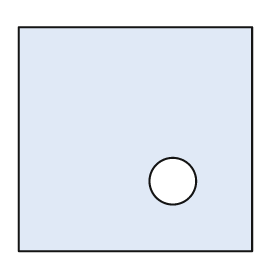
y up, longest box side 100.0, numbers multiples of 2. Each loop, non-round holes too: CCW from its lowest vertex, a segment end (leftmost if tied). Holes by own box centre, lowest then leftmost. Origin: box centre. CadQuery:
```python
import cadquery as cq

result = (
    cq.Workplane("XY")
    .moveTo(-50.0, -48.0)
    .lineTo(50.0, -48.0)
    .lineTo(50.0, 48.0)
    .lineTo(-50.0, 48.0)
    .close()
    .moveTo(16.0, -18.0)
    .circle(10.0)
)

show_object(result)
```